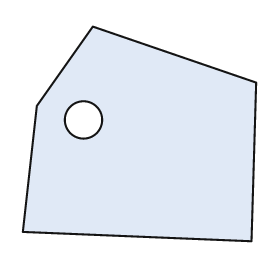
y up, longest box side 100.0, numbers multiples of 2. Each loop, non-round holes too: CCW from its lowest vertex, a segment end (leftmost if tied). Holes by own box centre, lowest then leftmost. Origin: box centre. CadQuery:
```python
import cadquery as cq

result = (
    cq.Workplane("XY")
    .moveTo(48.0, -46.0)
    .lineTo(50.0, 22.0)
    .lineTo(-20.0, 46.0)
    .lineTo(-44.0, 12.0)
    .lineTo(-50.0, -42.0)
    .close()
    .moveTo(-24.0, 6.0)
    .circle(8.0)
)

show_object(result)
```